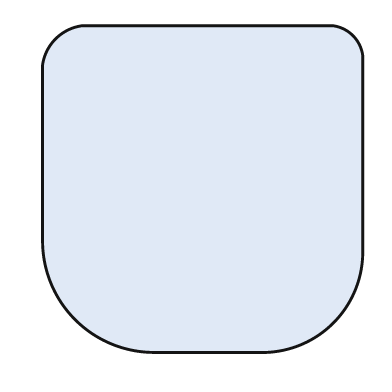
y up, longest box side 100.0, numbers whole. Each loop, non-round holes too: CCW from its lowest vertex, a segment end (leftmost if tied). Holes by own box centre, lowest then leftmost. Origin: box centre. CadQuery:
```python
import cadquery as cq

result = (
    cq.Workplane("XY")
    .moveTo(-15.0, -50.0)
    .lineTo(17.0, -50.0)
    .threePointArc((40.0, -41.0), (49.0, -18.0))
    .lineTo(49.0, 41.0)
    .threePointArc((46.0, 47.0), (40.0, 50.0))
    .lineTo(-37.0, 50.0)
    .threePointArc((-45.0, 46.0), (-49.0, 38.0))
    .lineTo(-49.0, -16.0)
    .threePointArc((-39.0, -40.0), (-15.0, -50.0))
    .close()
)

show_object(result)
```